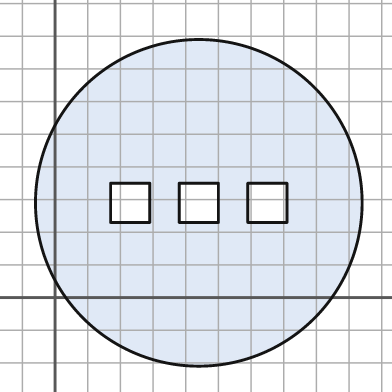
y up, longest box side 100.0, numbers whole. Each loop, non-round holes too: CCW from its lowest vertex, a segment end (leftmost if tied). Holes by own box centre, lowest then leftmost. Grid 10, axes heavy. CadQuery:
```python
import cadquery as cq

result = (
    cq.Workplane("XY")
    .moveTo(44.0, 29.0)
    .circle(50.0)
    .moveTo(17.0, 23.0)
    .lineTo(29.0, 23.0)
    .lineTo(29.0, 35.0)
    .lineTo(17.0, 35.0)
    .close()
    .moveTo(38.0, 23.0)
    .lineTo(50.0, 23.0)
    .lineTo(50.0, 35.0)
    .lineTo(38.0, 35.0)
    .close()
    .moveTo(59.0, 23.0)
    .lineTo(71.0, 23.0)
    .lineTo(71.0, 35.0)
    .lineTo(59.0, 35.0)
    .close()
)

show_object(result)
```